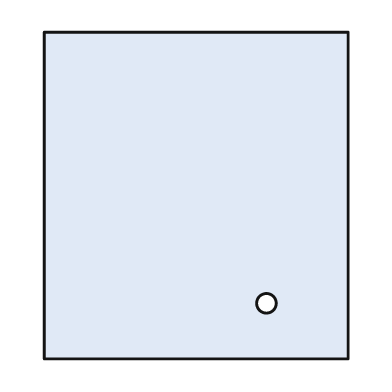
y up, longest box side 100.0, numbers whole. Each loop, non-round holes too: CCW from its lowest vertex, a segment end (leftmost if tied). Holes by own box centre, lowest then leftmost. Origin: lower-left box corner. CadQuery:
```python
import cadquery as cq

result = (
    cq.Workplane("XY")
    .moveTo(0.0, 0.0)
    .lineTo(93.0, 0.0)
    .lineTo(93.0, 100.0)
    .lineTo(0.0, 100.0)
    .close()
    .moveTo(68.0, 17.0)
    .circle(3.0)
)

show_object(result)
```